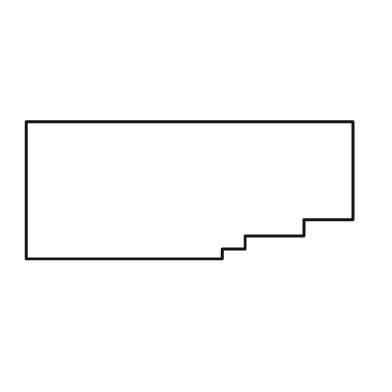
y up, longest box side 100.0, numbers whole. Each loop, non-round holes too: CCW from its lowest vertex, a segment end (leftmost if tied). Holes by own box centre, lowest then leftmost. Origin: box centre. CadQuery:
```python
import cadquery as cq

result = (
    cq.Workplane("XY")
    .moveTo(-50.0, -21.0)
    .lineTo(10.0, -21.0)
    .lineTo(10.0, -18.0)
    .lineTo(17.0, -18.0)
    .lineTo(17.0, -14.0)
    .lineTo(35.0, -14.0)
    .lineTo(35.0, -9.0)
    .lineTo(50.0, -9.0)
    .lineTo(50.0, 21.0)
    .lineTo(-50.0, 21.0)
    .close()
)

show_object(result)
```